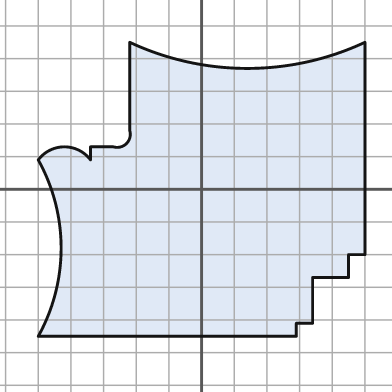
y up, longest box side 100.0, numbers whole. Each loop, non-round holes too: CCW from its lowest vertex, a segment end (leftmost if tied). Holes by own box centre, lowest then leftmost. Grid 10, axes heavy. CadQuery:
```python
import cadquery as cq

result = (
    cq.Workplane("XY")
    .moveTo(-50.0, -45.0)
    .lineTo(29.0, -45.0)
    .lineTo(29.0, -41.0)
    .lineTo(34.0, -41.0)
    .lineTo(34.0, -27.0)
    .lineTo(45.0, -27.0)
    .lineTo(45.0, -20.0)
    .lineTo(50.0, -20.0)
    .lineTo(50.0, 45.0)
    .threePointArc((14.0, 37.0), (-22.0, 45.0))
    .lineTo(-22.0, 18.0)
    .threePointArc((-23.0, 14.0), (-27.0, 13.0))
    .lineTo(-34.0, 13.0)
    .lineTo(-34.0, 9.0)
    .threePointArc((-42.0, 13.0), (-50.0, 9.0))
    .threePointArc((-43.0, -18.0), (-50.0, -45.0))
    .close()
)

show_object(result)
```